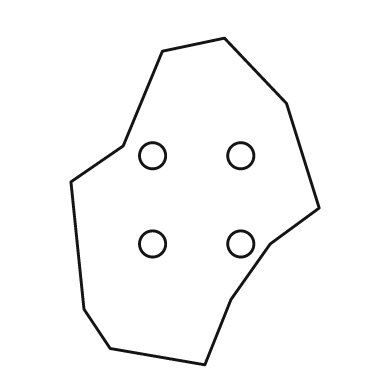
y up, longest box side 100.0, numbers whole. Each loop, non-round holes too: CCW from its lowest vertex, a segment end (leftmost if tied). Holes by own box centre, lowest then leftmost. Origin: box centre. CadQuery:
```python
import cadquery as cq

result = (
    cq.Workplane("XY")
    .moveTo(3.0, -50.0)
    .lineTo(11.0, -30.0)
    .lineTo(23.0, -13.0)
    .lineTo(38.0, -2.0)
    .lineTo(28.0, 30.0)
    .lineTo(9.0, 50.0)
    .lineTo(-10.0, 46.0)
    .lineTo(-22.0, 17.0)
    .lineTo(-38.0, 6.0)
    .lineTo(-34.0, -33.0)
    .lineTo(-26.0, -45.0)
    .close()
    .moveTo(-13.0, -13.0)
    .circle(4.0)
    .moveTo(14.0, -13.0)
    .circle(4.0)
    .moveTo(-13.0, 14.0)
    .circle(4.0)
    .moveTo(14.0, 14.0)
    .circle(4.0)
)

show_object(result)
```